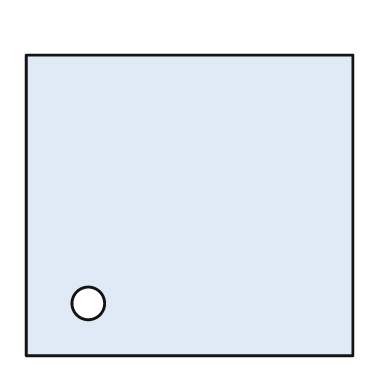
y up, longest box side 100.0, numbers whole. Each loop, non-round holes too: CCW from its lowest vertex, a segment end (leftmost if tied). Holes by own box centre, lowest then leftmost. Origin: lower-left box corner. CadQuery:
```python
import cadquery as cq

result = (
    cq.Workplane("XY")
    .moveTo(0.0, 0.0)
    .lineTo(100.0, 0.0)
    .lineTo(100.0, 92.0)
    .lineTo(0.0, 92.0)
    .close()
    .moveTo(19.0, 16.0)
    .circle(5.0)
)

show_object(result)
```